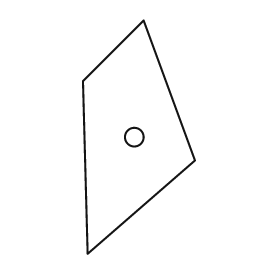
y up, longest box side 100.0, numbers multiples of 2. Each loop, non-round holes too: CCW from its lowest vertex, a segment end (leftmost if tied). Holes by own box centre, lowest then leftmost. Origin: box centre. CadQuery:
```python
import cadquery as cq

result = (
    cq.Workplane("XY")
    .moveTo(-22.0, -50.0)
    .lineTo(24.0, -10.0)
    .lineTo(2.0, 50.0)
    .lineTo(-24.0, 24.0)
    .close()
    .moveTo(-2.0, 0.0)
    .circle(4.0)
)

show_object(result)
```